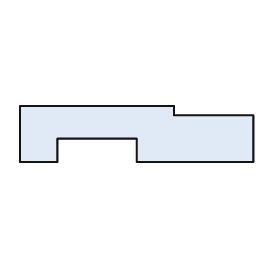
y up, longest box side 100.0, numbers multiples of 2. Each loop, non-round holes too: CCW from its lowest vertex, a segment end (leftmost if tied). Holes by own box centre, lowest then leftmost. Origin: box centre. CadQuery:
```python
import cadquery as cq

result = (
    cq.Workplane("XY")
    .moveTo(-50.0, -12.0)
    .lineTo(-34.0, -12.0)
    .lineTo(-34.0, -2.0)
    .lineTo(0.0, -2.0)
    .lineTo(0.0, -12.0)
    .lineTo(50.0, -12.0)
    .lineTo(50.0, 8.0)
    .lineTo(16.0, 8.0)
    .lineTo(16.0, 12.0)
    .lineTo(-50.0, 12.0)
    .close()
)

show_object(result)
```